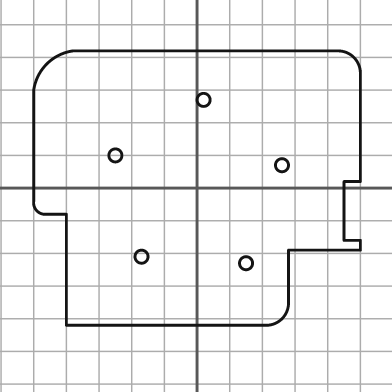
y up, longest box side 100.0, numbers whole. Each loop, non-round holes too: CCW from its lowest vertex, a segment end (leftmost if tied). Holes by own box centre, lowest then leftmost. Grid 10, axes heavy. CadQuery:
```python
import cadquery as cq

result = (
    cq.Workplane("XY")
    .moveTo(-40.0, -42.0)
    .lineTo(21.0, -42.0)
    .threePointArc((26.0, -40.0), (28.0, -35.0))
    .lineTo(28.0, -19.0)
    .lineTo(50.0, -19.0)
    .lineTo(50.0, -16.0)
    .lineTo(45.0, -16.0)
    .lineTo(45.0, 2.0)
    .lineTo(50.0, 2.0)
    .lineTo(50.0, 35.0)
    .threePointArc((48.0, 40.0), (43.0, 42.0))
    .lineTo(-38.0, 42.0)
    .threePointArc((-46.0, 38.0), (-50.0, 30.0))
    .lineTo(-50.0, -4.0)
    .threePointArc((-49.0, -7.0), (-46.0, -8.0))
    .lineTo(-40.0, -8.0)
    .close()
    .moveTo(15.0, -23.0)
    .circle(2.0)
    .moveTo(-17.0, -21.0)
    .circle(2.0)
    .moveTo(26.0, 7.0)
    .circle(2.0)
    .moveTo(-25.0, 10.0)
    .circle(2.0)
    .moveTo(2.0, 27.0)
    .circle(2.0)
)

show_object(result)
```